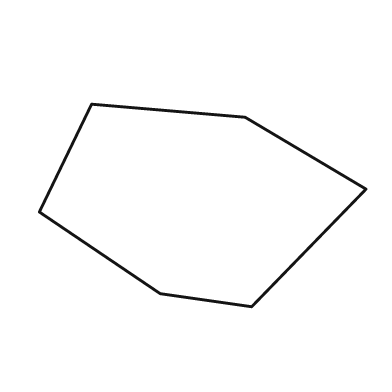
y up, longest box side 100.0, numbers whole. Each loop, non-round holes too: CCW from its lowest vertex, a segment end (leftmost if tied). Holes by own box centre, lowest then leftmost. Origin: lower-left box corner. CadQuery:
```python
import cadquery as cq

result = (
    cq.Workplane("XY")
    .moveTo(65.0, 0.0)
    .lineTo(100.0, 36.0)
    .lineTo(63.0, 58.0)
    .lineTo(16.0, 62.0)
    .lineTo(0.0, 29.0)
    .lineTo(37.0, 4.0)
    .close()
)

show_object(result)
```